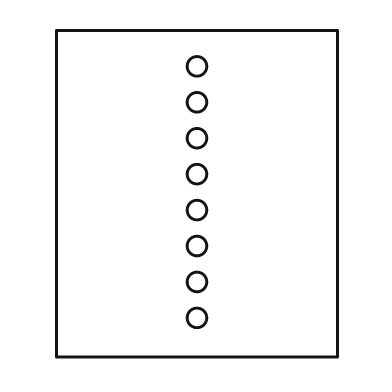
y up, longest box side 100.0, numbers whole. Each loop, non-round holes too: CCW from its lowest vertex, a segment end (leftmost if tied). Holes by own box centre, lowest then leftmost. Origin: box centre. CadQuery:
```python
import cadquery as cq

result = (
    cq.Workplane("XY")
    .moveTo(-43.0, -50.0)
    .lineTo(43.0, -50.0)
    .lineTo(43.0, 50.0)
    .lineTo(-43.0, 50.0)
    .close()
    .moveTo(0.0, -38.0)
    .circle(3.0)
    .moveTo(0.0, -27.0)
    .circle(3.0)
    .moveTo(0.0, -16.0)
    .circle(3.0)
    .moveTo(0.0, -5.0)
    .circle(3.0)
    .moveTo(0.0, 6.0)
    .circle(3.0)
    .moveTo(0.0, 17.0)
    .circle(3.0)
    .moveTo(0.0, 28.0)
    .circle(3.0)
    .moveTo(0.0, 39.0)
    .circle(3.0)
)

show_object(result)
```